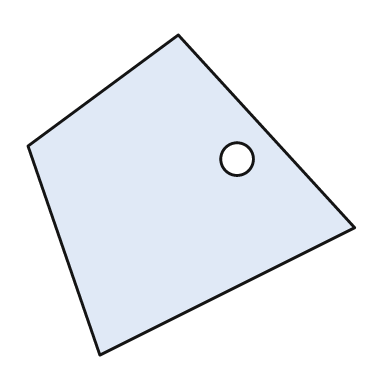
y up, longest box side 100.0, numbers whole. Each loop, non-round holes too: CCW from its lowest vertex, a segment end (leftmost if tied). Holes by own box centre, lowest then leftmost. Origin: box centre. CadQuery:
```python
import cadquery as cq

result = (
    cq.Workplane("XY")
    .moveTo(-28.0, -49.0)
    .lineTo(50.0, -10.0)
    .lineTo(-4.0, 49.0)
    .lineTo(-50.0, 15.0)
    .close()
    .moveTo(14.0, 11.0)
    .circle(5.0)
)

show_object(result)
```